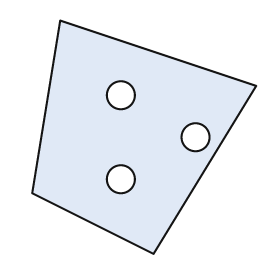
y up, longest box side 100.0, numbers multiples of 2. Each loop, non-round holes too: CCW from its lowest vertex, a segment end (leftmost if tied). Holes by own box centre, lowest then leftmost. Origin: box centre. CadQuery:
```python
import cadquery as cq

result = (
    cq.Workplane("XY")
    .moveTo(4.0, -50.0)
    .lineTo(48.0, 22.0)
    .lineTo(-36.0, 50.0)
    .lineTo(-48.0, -24.0)
    .close()
    .moveTo(-10.0, -18.0)
    .circle(6.0)
    .moveTo(22.0, 0.0)
    .circle(6.0)
    .moveTo(-10.0, 18.0)
    .circle(6.0)
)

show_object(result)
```